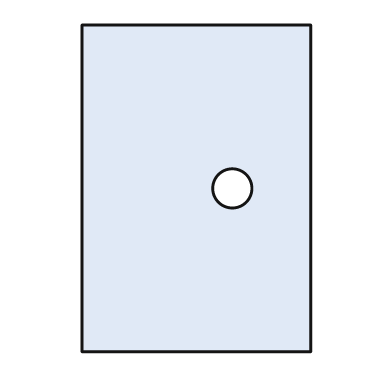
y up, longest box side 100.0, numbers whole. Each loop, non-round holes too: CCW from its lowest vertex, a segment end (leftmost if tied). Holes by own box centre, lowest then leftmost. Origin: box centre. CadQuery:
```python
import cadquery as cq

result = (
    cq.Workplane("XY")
    .moveTo(-35.0, -50.0)
    .lineTo(35.0, -50.0)
    .lineTo(35.0, 50.0)
    .lineTo(-35.0, 50.0)
    .close()
    .moveTo(11.0, 0.0)
    .circle(6.0)
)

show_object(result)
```